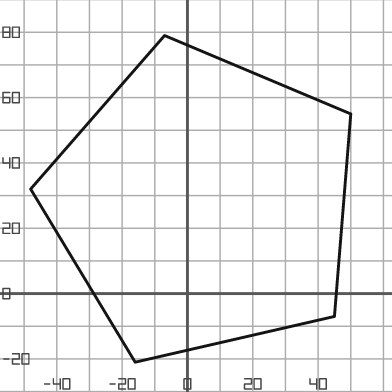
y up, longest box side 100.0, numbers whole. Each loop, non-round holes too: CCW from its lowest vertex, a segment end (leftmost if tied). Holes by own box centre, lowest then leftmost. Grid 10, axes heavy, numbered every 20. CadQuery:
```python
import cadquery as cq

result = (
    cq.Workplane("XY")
    .moveTo(-16.0, -21.0)
    .lineTo(45.0, -7.0)
    .lineTo(50.0, 55.0)
    .lineTo(-7.0, 79.0)
    .lineTo(-48.0, 32.0)
    .close()
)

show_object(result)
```